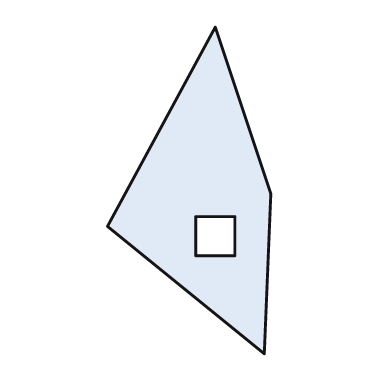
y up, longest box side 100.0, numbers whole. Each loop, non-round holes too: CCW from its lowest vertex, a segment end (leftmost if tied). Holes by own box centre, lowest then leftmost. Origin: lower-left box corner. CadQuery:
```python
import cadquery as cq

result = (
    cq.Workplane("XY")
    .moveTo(48.0, 0.0)
    .lineTo(50.0, 49.0)
    .lineTo(33.0, 100.0)
    .lineTo(0.0, 39.0)
    .close()
    .moveTo(27.0, 30.0)
    .lineTo(39.0, 30.0)
    .lineTo(39.0, 42.0)
    .lineTo(27.0, 42.0)
    .close()
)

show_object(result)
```